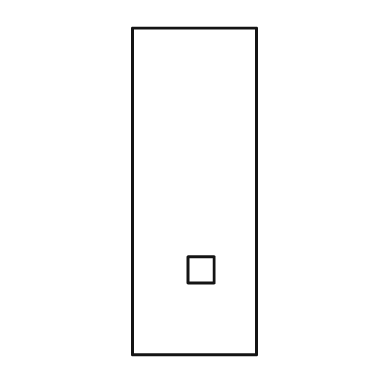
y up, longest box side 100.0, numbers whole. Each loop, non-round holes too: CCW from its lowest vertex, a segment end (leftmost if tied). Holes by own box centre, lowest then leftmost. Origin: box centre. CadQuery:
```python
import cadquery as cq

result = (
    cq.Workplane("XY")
    .moveTo(-19.0, -50.0)
    .lineTo(19.0, -50.0)
    .lineTo(19.0, 50.0)
    .lineTo(-19.0, 50.0)
    .close()
    .moveTo(-2.0, -28.0)
    .lineTo(6.0, -28.0)
    .lineTo(6.0, -20.0)
    .lineTo(-2.0, -20.0)
    .close()
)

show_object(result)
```